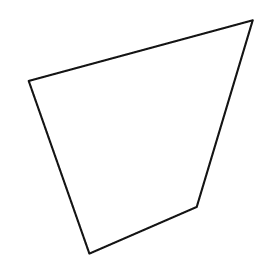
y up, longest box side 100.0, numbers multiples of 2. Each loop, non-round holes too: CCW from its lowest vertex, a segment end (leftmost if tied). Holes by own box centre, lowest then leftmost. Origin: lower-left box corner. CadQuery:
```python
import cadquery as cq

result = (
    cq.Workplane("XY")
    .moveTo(26.0, 0.0)
    .lineTo(72.0, 20.0)
    .lineTo(96.0, 100.0)
    .lineTo(0.0, 74.0)
    .close()
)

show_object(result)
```